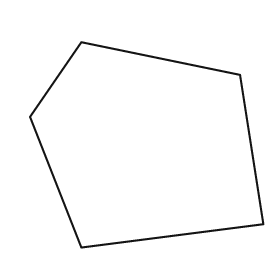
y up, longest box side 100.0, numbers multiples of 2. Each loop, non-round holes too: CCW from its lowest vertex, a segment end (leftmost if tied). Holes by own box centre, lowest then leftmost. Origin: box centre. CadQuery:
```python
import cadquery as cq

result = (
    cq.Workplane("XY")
    .moveTo(-28.0, -44.0)
    .lineTo(50.0, -34.0)
    .lineTo(40.0, 30.0)
    .lineTo(-28.0, 44.0)
    .lineTo(-50.0, 12.0)
    .close()
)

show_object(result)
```